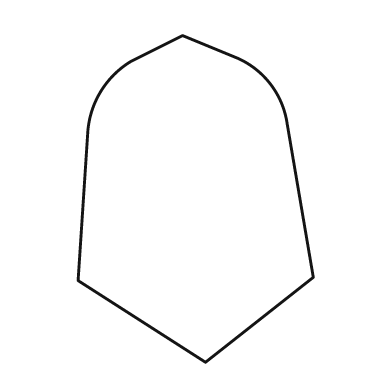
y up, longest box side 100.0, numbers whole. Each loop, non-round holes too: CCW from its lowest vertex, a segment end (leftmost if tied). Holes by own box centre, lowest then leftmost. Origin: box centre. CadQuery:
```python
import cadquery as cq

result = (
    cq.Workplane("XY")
    .moveTo(3.0, -50.0)
    .lineTo(36.0, -24.0)
    .lineTo(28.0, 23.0)
    .threePointArc((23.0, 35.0), (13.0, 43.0))
    .lineTo(-4.0, 50.0)
    .lineTo(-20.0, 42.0)
    .threePointArc((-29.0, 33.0), (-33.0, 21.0))
    .lineTo(-36.0, -25.0)
    .close()
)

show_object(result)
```